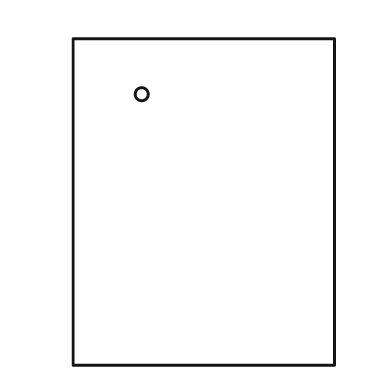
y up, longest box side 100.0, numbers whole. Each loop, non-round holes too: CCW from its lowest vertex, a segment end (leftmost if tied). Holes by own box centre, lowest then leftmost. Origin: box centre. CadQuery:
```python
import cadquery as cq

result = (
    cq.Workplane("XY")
    .moveTo(-40.0, -50.0)
    .lineTo(40.0, -50.0)
    .lineTo(40.0, 50.0)
    .lineTo(-40.0, 50.0)
    .close()
    .moveTo(-19.0, 33.0)
    .circle(2.0)
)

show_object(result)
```